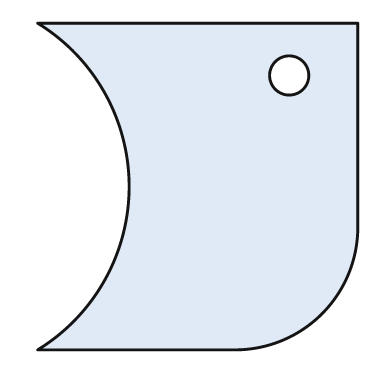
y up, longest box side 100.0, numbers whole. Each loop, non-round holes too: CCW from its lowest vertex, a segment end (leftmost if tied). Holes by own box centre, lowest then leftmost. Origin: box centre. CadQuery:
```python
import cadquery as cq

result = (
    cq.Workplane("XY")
    .moveTo(-49.0, -50.0)
    .lineTo(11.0, -50.0)
    .threePointArc((38.0, -39.0), (49.0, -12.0))
    .lineTo(49.0, 50.0)
    .lineTo(-49.0, 50.0)
    .threePointArc((-21.0, 0.0), (-49.0, -50.0))
    .close()
    .moveTo(28.0, 34.0)
    .circle(6.0)
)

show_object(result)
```